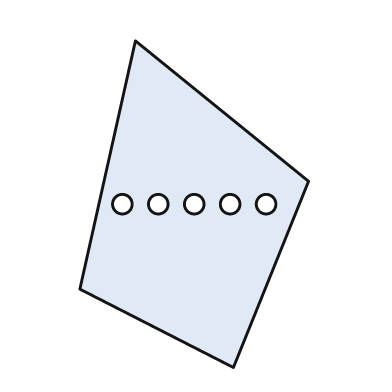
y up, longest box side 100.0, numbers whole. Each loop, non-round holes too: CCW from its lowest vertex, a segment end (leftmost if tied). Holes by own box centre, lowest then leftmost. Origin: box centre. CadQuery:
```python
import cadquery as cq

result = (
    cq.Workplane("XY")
    .moveTo(12.0, -50.0)
    .lineTo(35.0, 7.0)
    .lineTo(-18.0, 50.0)
    .lineTo(-35.0, -26.0)
    .close()
    .moveTo(-22.0, 0.0)
    .circle(3.0)
    .moveTo(-11.0, 0.0)
    .circle(3.0)
    .moveTo(0.0, 0.0)
    .circle(3.0)
    .moveTo(11.0, 0.0)
    .circle(3.0)
    .moveTo(22.0, 0.0)
    .circle(3.0)
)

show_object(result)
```